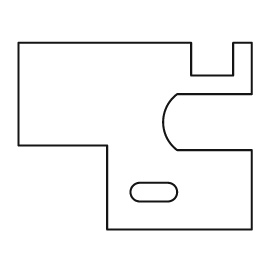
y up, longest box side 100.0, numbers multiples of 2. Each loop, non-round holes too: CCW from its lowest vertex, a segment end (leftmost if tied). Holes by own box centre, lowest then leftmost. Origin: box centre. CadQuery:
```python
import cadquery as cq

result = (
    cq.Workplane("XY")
    .moveTo(-12.0, -40.0)
    .lineTo(50.0, -40.0)
    .lineTo(50.0, -6.0)
    .lineTo(18.0, -6.0)
    .threePointArc((12.0, 6.0), (18.0, 18.0))
    .lineTo(50.0, 18.0)
    .lineTo(50.0, 40.0)
    .lineTo(42.0, 40.0)
    .lineTo(42.0, 26.0)
    .lineTo(24.0, 26.0)
    .lineTo(24.0, 40.0)
    .lineTo(-50.0, 40.0)
    .lineTo(-50.0, -4.0)
    .lineTo(-12.0, -4.0)
    .close()
    .moveTo(2.0, -28.0)
    .lineTo(14.0, -28.0)
    .threePointArc((18.0, -24.0), (14.0, -20.0))
    .lineTo(2.0, -20.0)
    .threePointArc((-2.0, -24.0), (2.0, -28.0))
    .close()
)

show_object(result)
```